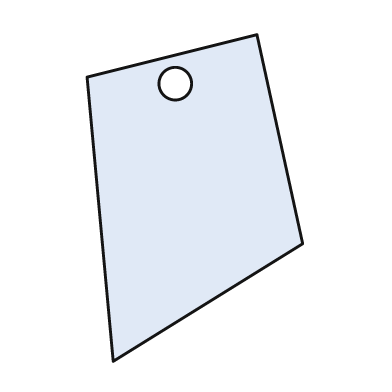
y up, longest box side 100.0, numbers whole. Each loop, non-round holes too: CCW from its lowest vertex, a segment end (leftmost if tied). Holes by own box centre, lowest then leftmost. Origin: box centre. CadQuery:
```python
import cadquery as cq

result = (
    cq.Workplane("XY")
    .moveTo(-25.0, -50.0)
    .lineTo(33.0, -14.0)
    .lineTo(19.0, 50.0)
    .lineTo(-33.0, 37.0)
    .close()
    .moveTo(-6.0, 35.0)
    .circle(5.0)
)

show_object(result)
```